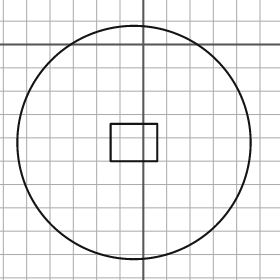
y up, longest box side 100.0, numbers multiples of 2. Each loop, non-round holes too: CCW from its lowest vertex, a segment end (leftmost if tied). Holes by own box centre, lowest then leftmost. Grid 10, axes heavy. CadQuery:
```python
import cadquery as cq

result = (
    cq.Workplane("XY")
    .moveTo(-4.0, -42.0)
    .circle(50.0)
    .moveTo(-14.0, -50.0)
    .lineTo(6.0, -50.0)
    .lineTo(6.0, -34.0)
    .lineTo(-14.0, -34.0)
    .close()
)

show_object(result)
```